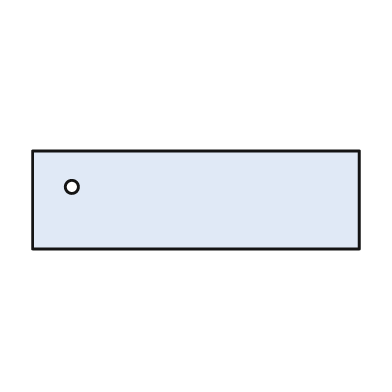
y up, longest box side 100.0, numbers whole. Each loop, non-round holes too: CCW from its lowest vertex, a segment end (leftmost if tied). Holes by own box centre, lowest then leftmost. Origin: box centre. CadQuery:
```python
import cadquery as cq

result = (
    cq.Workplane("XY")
    .moveTo(-50.0, -15.0)
    .lineTo(50.0, -15.0)
    .lineTo(50.0, 15.0)
    .lineTo(-50.0, 15.0)
    .close()
    .moveTo(-38.0, 4.0)
    .circle(2.0)
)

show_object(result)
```